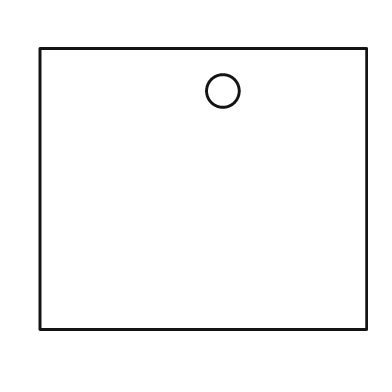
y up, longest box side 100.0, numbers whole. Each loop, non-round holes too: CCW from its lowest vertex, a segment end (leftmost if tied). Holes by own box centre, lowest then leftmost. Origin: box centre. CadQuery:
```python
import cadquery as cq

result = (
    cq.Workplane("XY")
    .moveTo(-50.0, -43.0)
    .lineTo(50.0, -43.0)
    .lineTo(50.0, 43.0)
    .lineTo(-50.0, 43.0)
    .close()
    .moveTo(6.0, 30.0)
    .circle(5.0)
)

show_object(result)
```